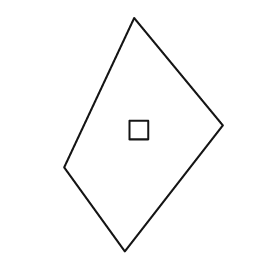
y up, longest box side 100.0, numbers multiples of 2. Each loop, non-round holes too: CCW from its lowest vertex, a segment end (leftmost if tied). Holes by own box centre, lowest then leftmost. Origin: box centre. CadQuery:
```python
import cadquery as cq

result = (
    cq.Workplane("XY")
    .moveTo(-8.0, -50.0)
    .lineTo(34.0, 4.0)
    .lineTo(-4.0, 50.0)
    .lineTo(-34.0, -14.0)
    .close()
    .moveTo(-6.0, -2.0)
    .lineTo(2.0, -2.0)
    .lineTo(2.0, 6.0)
    .lineTo(-6.0, 6.0)
    .close()
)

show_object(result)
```